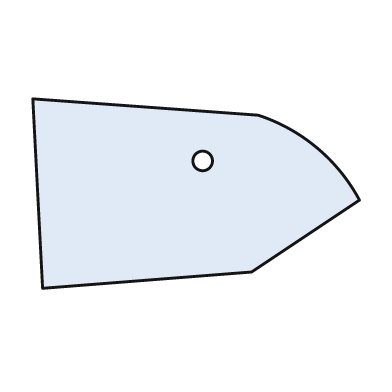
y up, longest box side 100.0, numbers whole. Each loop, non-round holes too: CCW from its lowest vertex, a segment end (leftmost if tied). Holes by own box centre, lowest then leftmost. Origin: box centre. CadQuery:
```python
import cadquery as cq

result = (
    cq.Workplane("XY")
    .moveTo(-47.0, -29.0)
    .lineTo(17.0, -24.0)
    .lineTo(50.0, -2.0)
    .threePointArc((37.0, 14.0), (19.0, 24.0))
    .lineTo(-50.0, 29.0)
    .close()
    .moveTo(2.0, 10.0)
    .circle(3.0)
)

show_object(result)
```